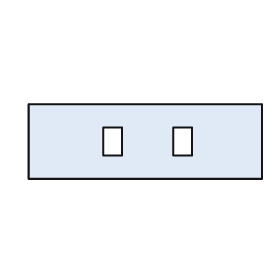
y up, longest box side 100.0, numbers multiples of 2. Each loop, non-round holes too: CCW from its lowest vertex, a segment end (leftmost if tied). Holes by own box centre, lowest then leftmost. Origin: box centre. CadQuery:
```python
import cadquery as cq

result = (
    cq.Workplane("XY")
    .moveTo(-50.0, -16.0)
    .lineTo(50.0, -16.0)
    .lineTo(50.0, 16.0)
    .lineTo(-50.0, 16.0)
    .close()
    .moveTo(-18.0, -6.0)
    .lineTo(-10.0, -6.0)
    .lineTo(-10.0, 6.0)
    .lineTo(-18.0, 6.0)
    .close()
    .moveTo(12.0, -6.0)
    .lineTo(20.0, -6.0)
    .lineTo(20.0, 6.0)
    .lineTo(12.0, 6.0)
    .close()
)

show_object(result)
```